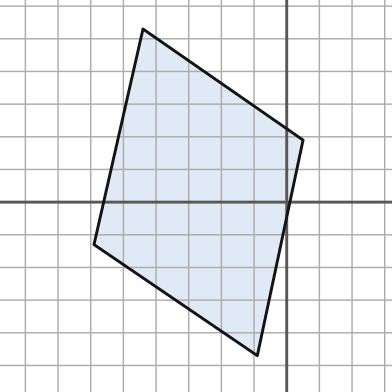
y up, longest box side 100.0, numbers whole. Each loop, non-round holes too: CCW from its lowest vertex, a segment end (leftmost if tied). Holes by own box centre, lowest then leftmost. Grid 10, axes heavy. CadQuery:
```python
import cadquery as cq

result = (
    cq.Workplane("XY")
    .moveTo(-9.0, -47.0)
    .lineTo(5.0, 19.0)
    .lineTo(-44.0, 53.0)
    .lineTo(-59.0, -13.0)
    .close()
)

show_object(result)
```